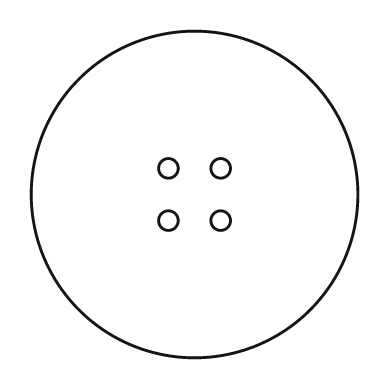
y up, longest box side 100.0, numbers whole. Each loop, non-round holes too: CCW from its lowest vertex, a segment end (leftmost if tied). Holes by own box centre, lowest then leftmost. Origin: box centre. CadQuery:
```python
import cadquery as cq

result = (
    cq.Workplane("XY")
    .moveTo(0.0, 0.0)
    .circle(50.0)
    .moveTo(-8.0, -8.0)
    .circle(3.0)
    .moveTo(8.0, -8.0)
    .circle(3.0)
    .moveTo(-8.0, 8.0)
    .circle(3.0)
    .moveTo(8.0, 8.0)
    .circle(3.0)
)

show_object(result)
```